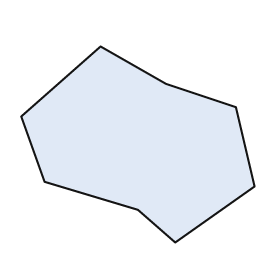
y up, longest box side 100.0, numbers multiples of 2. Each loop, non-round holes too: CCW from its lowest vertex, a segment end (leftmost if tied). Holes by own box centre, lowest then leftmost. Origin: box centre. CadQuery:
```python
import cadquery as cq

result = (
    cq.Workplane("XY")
    .moveTo(16.0, -42.0)
    .lineTo(50.0, -18.0)
    .lineTo(42.0, 16.0)
    .lineTo(12.0, 26.0)
    .lineTo(-16.0, 42.0)
    .lineTo(-50.0, 12.0)
    .lineTo(-40.0, -16.0)
    .lineTo(0.0, -28.0)
    .close()
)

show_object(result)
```